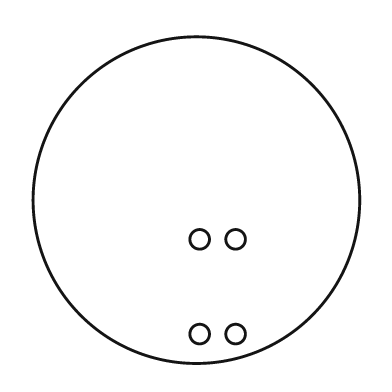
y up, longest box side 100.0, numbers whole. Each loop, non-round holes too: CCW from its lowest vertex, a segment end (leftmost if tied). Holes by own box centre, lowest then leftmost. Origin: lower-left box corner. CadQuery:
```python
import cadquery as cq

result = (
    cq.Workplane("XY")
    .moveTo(50.0, 50.0)
    .circle(50.0)
    .moveTo(51.0, 9.0)
    .circle(3.0)
    .moveTo(62.0, 9.0)
    .circle(3.0)
    .moveTo(51.0, 38.0)
    .circle(3.0)
    .moveTo(62.0, 38.0)
    .circle(3.0)
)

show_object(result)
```